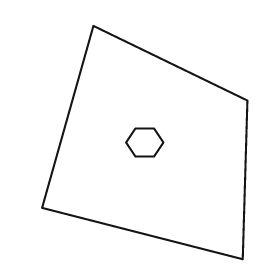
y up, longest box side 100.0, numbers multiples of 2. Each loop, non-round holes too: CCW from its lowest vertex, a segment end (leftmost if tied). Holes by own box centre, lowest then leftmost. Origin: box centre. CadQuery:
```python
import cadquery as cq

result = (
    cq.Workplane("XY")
    .moveTo(42.0, -50.0)
    .lineTo(44.0, 18.0)
    .lineTo(-22.0, 50.0)
    .lineTo(-44.0, -28.0)
    .close()
    .moveTo(-4.0, -6.0)
    .lineTo(4.0, -6.0)
    .lineTo(8.0, 0.0)
    .lineTo(4.0, 6.0)
    .lineTo(-4.0, 6.0)
    .lineTo(-8.0, 0.0)
    .close()
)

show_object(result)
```